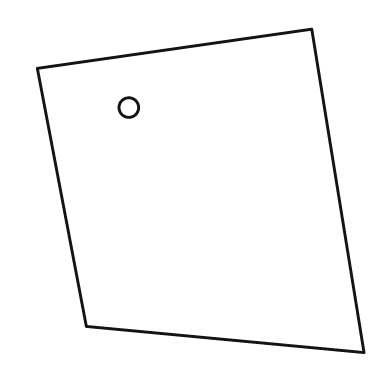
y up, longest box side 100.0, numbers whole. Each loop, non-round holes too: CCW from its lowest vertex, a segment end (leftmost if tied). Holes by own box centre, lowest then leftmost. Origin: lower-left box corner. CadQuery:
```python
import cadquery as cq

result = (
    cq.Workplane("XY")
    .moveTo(100.0, 0.0)
    .lineTo(84.0, 99.0)
    .lineTo(0.0, 87.0)
    .lineTo(15.0, 8.0)
    .close()
    .moveTo(28.0, 75.0)
    .circle(3.0)
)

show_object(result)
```